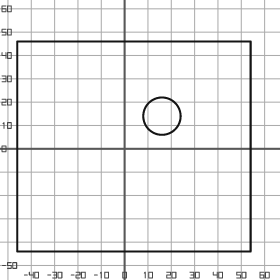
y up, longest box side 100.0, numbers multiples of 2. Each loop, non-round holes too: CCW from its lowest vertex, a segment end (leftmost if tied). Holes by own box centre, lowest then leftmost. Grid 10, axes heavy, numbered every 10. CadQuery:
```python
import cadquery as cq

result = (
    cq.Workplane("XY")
    .moveTo(-46.0, -44.0)
    .lineTo(54.0, -44.0)
    .lineTo(54.0, 46.0)
    .lineTo(-46.0, 46.0)
    .close()
    .moveTo(16.0, 14.0)
    .circle(8.0)
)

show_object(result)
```